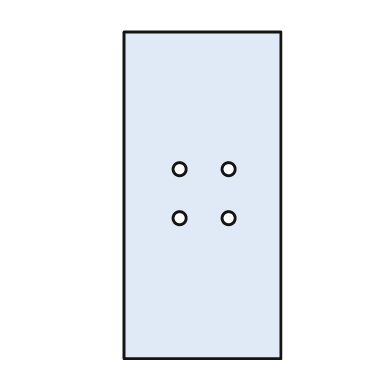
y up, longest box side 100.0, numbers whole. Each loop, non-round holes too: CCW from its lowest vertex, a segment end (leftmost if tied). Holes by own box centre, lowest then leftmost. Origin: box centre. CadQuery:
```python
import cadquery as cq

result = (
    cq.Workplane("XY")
    .moveTo(-24.0, -50.0)
    .lineTo(24.0, -50.0)
    .lineTo(24.0, 50.0)
    .lineTo(-24.0, 50.0)
    .close()
    .moveTo(-7.0, -7.0)
    .circle(2.0)
    .moveTo(8.0, -7.0)
    .circle(2.0)
    .moveTo(-7.0, 8.0)
    .circle(2.0)
    .moveTo(8.0, 8.0)
    .circle(2.0)
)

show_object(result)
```